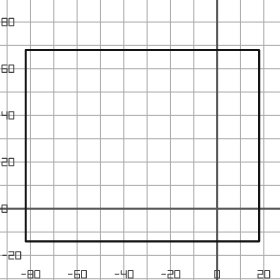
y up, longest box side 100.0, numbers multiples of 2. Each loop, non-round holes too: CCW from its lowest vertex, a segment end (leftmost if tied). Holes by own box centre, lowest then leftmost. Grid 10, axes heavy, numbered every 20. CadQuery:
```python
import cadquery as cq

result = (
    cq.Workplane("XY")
    .moveTo(-82.0, -14.0)
    .lineTo(18.0, -14.0)
    .lineTo(18.0, 68.0)
    .lineTo(-82.0, 68.0)
    .close()
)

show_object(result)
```